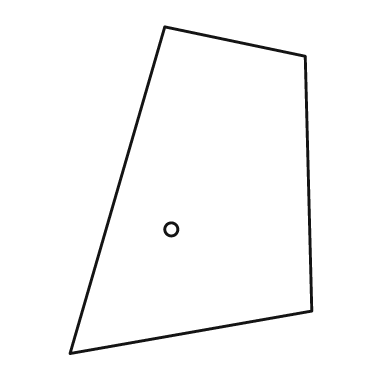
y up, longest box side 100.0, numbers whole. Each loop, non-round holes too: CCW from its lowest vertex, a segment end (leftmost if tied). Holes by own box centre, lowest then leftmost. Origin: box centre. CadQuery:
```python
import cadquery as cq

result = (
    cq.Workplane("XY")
    .moveTo(-37.0, -50.0)
    .lineTo(37.0, -37.0)
    .lineTo(35.0, 41.0)
    .lineTo(-8.0, 50.0)
    .close()
    .moveTo(-6.0, -12.0)
    .circle(2.0)
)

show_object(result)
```